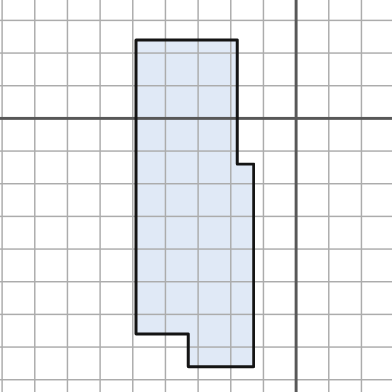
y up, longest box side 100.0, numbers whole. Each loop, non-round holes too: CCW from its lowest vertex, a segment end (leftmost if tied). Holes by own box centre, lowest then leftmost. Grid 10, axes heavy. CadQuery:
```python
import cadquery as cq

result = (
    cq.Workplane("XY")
    .moveTo(-33.0, -76.0)
    .lineTo(-13.0, -76.0)
    .lineTo(-13.0, -14.0)
    .lineTo(-18.0, -14.0)
    .lineTo(-18.0, 24.0)
    .lineTo(-49.0, 24.0)
    .lineTo(-49.0, -66.0)
    .lineTo(-33.0, -66.0)
    .close()
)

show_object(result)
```